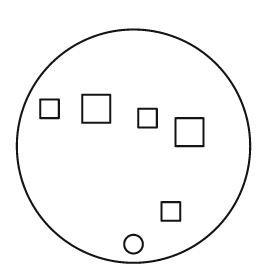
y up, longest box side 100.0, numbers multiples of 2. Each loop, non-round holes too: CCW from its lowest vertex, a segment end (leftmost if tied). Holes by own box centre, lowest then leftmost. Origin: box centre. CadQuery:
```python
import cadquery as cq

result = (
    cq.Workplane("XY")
    .moveTo(0.0, 0.0)
    .circle(50.0)
    .moveTo(0.0, -42.0)
    .circle(4.0)
    .moveTo(12.0, -32.0)
    .lineTo(20.0, -32.0)
    .lineTo(20.0, -24.0)
    .lineTo(12.0, -24.0)
    .close()
    .moveTo(18.0, 0.0)
    .lineTo(30.0, 0.0)
    .lineTo(30.0, 12.0)
    .lineTo(18.0, 12.0)
    .close()
    .moveTo(2.0, 8.0)
    .lineTo(10.0, 8.0)
    .lineTo(10.0, 16.0)
    .lineTo(2.0, 16.0)
    .close()
    .moveTo(-40.0, 12.0)
    .lineTo(-32.0, 12.0)
    .lineTo(-32.0, 20.0)
    .lineTo(-40.0, 20.0)
    .close()
    .moveTo(-22.0, 10.0)
    .lineTo(-10.0, 10.0)
    .lineTo(-10.0, 22.0)
    .lineTo(-22.0, 22.0)
    .close()
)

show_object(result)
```